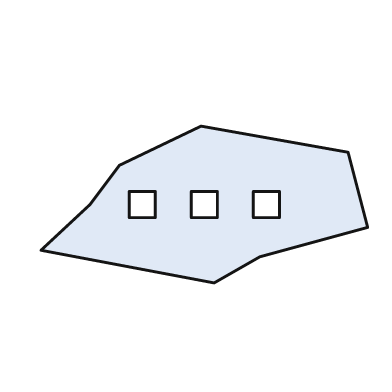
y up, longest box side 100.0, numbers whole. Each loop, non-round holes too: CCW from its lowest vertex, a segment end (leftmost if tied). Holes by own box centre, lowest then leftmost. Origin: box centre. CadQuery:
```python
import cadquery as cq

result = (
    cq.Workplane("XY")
    .moveTo(3.0, -24.0)
    .lineTo(17.0, -16.0)
    .lineTo(50.0, -7.0)
    .lineTo(44.0, 16.0)
    .lineTo(-1.0, 24.0)
    .lineTo(-26.0, 12.0)
    .lineTo(-35.0, 0.0)
    .lineTo(-50.0, -14.0)
    .close()
    .moveTo(-23.0, -4.0)
    .lineTo(-15.0, -4.0)
    .lineTo(-15.0, 4.0)
    .lineTo(-23.0, 4.0)
    .close()
    .moveTo(-4.0, -4.0)
    .lineTo(4.0, -4.0)
    .lineTo(4.0, 4.0)
    .lineTo(-4.0, 4.0)
    .close()
    .moveTo(15.0, -4.0)
    .lineTo(23.0, -4.0)
    .lineTo(23.0, 4.0)
    .lineTo(15.0, 4.0)
    .close()
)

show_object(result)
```